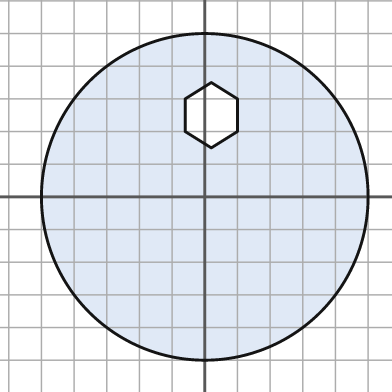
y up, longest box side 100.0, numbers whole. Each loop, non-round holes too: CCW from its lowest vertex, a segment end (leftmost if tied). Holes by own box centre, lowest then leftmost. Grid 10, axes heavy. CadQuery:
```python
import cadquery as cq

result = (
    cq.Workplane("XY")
    .moveTo(0.0, 0.0)
    .circle(50.0)
    .moveTo(2.0, 15.0)
    .lineTo(10.0, 20.0)
    .lineTo(10.0, 30.0)
    .lineTo(2.0, 35.0)
    .lineTo(-6.0, 30.0)
    .lineTo(-6.0, 20.0)
    .close()
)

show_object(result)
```